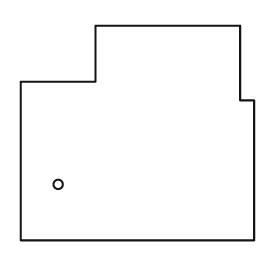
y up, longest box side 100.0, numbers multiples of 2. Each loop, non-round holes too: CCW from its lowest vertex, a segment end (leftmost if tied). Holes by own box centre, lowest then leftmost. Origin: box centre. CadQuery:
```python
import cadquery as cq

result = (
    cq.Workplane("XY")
    .moveTo(-50.0, -46.0)
    .lineTo(50.0, -46.0)
    .lineTo(50.0, 14.0)
    .lineTo(44.0, 14.0)
    .lineTo(44.0, 46.0)
    .lineTo(-18.0, 46.0)
    .lineTo(-18.0, 22.0)
    .lineTo(-50.0, 22.0)
    .close()
    .moveTo(-34.0, -22.0)
    .circle(2.0)
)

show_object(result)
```